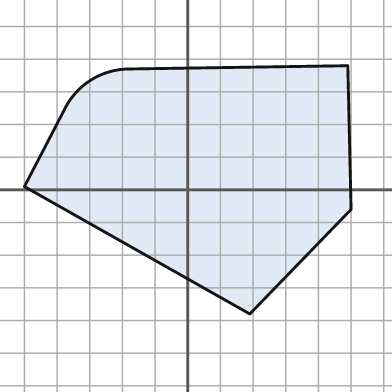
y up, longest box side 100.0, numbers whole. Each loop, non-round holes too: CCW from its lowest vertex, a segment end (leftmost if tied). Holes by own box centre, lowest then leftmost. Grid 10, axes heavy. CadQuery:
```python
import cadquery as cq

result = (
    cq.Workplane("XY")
    .moveTo(19.0, -38.0)
    .lineTo(50.0, -6.0)
    .lineTo(49.0, 38.0)
    .lineTo(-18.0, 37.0)
    .threePointArc((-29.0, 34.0), (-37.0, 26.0))
    .lineTo(-50.0, 1.0)
    .close()
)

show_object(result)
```